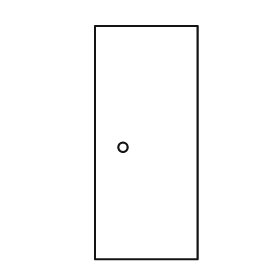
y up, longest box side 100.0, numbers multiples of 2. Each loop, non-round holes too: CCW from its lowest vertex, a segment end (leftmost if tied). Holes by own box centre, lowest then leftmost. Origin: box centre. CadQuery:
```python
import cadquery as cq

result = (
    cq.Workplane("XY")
    .moveTo(-22.0, -50.0)
    .lineTo(22.0, -50.0)
    .lineTo(22.0, 50.0)
    .lineTo(-22.0, 50.0)
    .close()
    .moveTo(-10.0, -2.0)
    .circle(2.0)
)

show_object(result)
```